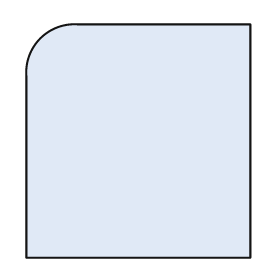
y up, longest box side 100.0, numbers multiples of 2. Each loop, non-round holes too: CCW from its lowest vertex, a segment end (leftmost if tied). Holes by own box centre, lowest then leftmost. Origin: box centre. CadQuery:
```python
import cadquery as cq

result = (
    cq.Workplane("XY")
    .moveTo(-48.0, -50.0)
    .lineTo(48.0, -50.0)
    .lineTo(48.0, 50.0)
    .lineTo(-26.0, 50.0)
    .threePointArc((-42.0, 44.0), (-48.0, 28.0))
    .close()
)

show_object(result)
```